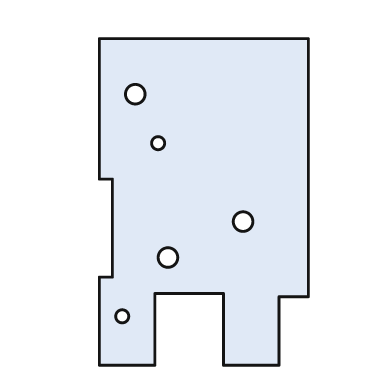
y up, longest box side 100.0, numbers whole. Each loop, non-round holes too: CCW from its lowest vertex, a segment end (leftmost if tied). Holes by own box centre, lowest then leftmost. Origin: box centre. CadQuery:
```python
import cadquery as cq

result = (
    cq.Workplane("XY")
    .moveTo(-32.0, -50.0)
    .lineTo(-15.0, -50.0)
    .lineTo(-15.0, -28.0)
    .lineTo(6.0, -28.0)
    .lineTo(6.0, -50.0)
    .lineTo(23.0, -50.0)
    .lineTo(23.0, -29.0)
    .lineTo(32.0, -29.0)
    .lineTo(32.0, 50.0)
    .lineTo(-32.0, 50.0)
    .lineTo(-32.0, 7.0)
    .lineTo(-28.0, 7.0)
    .lineTo(-28.0, -23.0)
    .lineTo(-32.0, -23.0)
    .close()
    .moveTo(-25.0, -35.0)
    .circle(2.0)
    .moveTo(-11.0, -17.0)
    .circle(3.0)
    .moveTo(12.0, -6.0)
    .circle(3.0)
    .moveTo(-14.0, 18.0)
    .circle(2.0)
    .moveTo(-21.0, 33.0)
    .circle(3.0)
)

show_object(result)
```